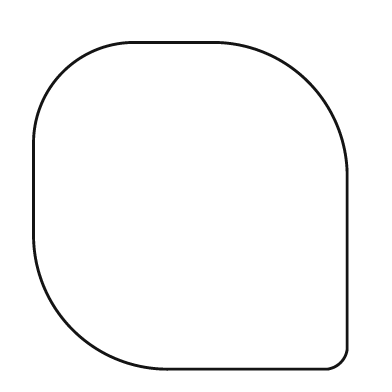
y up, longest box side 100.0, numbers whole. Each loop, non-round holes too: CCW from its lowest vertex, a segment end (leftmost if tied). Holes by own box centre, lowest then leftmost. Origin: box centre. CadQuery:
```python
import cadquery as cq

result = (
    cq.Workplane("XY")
    .moveTo(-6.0, -50.0)
    .lineTo(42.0, -50.0)
    .threePointArc((46.0, -48.0), (48.0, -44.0))
    .lineTo(48.0, 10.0)
    .threePointArc((36.0, 38.0), (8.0, 50.0))
    .lineTo(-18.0, 50.0)
    .threePointArc((-39.0, 41.0), (-48.0, 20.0))
    .lineTo(-48.0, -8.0)
    .threePointArc((-36.0, -38.0), (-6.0, -50.0))
    .close()
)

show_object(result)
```